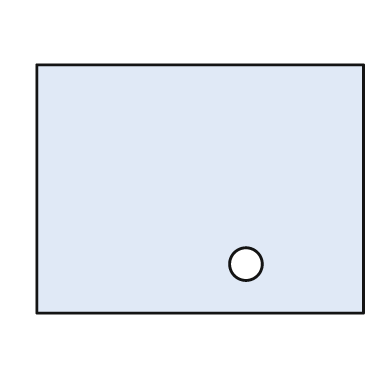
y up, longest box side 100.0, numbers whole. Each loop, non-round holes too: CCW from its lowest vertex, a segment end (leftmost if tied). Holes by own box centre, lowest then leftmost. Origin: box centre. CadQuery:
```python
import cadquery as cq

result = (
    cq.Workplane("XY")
    .moveTo(-50.0, -38.0)
    .lineTo(50.0, -38.0)
    .lineTo(50.0, 38.0)
    .lineTo(-50.0, 38.0)
    .close()
    .moveTo(14.0, -23.0)
    .circle(5.0)
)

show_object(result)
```